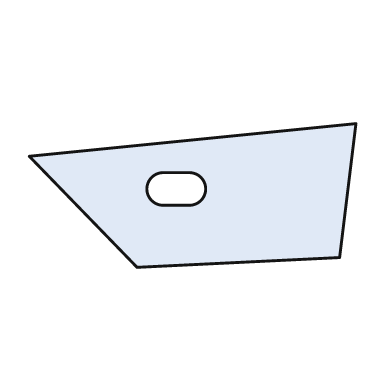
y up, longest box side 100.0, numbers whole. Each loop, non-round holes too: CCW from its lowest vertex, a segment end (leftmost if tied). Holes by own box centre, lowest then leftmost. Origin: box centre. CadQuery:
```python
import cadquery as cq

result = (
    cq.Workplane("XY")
    .moveTo(-17.0, -22.0)
    .lineTo(45.0, -19.0)
    .lineTo(50.0, 22.0)
    .lineTo(-50.0, 12.0)
    .close()
    .moveTo(-9.0, -3.0)
    .lineTo(-1.0, -3.0)
    .threePointArc((4.0, 2.0), (-1.0, 7.0))
    .lineTo(-9.0, 7.0)
    .threePointArc((-14.0, 2.0), (-9.0, -3.0))
    .close()
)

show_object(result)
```